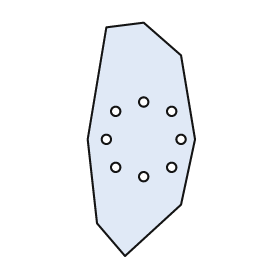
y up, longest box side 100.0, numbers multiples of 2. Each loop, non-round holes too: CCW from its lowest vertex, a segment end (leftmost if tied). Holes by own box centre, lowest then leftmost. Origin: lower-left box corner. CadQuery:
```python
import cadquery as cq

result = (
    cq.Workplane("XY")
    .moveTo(16.0, 0.0)
    .lineTo(40.0, 22.0)
    .lineTo(46.0, 50.0)
    .lineTo(40.0, 86.0)
    .lineTo(24.0, 100.0)
    .lineTo(8.0, 98.0)
    .lineTo(0.0, 50.0)
    .lineTo(4.0, 14.0)
    .close()
    .moveTo(24.0, 34.0)
    .circle(2.0)
    .moveTo(12.0, 38.0)
    .circle(2.0)
    .moveTo(36.0, 38.0)
    .circle(2.0)
    .moveTo(8.0, 50.0)
    .circle(2.0)
    .moveTo(40.0, 50.0)
    .circle(2.0)
    .moveTo(12.0, 62.0)
    .circle(2.0)
    .moveTo(36.0, 62.0)
    .circle(2.0)
    .moveTo(24.0, 66.0)
    .circle(2.0)
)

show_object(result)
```